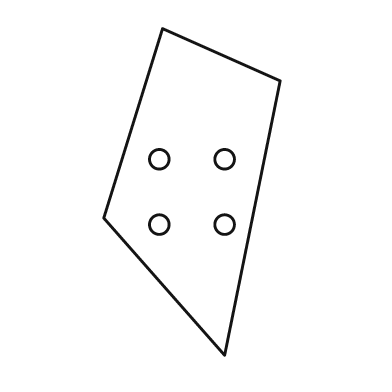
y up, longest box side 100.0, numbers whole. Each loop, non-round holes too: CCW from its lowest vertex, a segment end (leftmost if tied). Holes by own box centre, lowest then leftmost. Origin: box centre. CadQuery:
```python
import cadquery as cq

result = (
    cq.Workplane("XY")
    .moveTo(10.0, -50.0)
    .lineTo(27.0, 34.0)
    .lineTo(-9.0, 50.0)
    .lineTo(-27.0, -8.0)
    .close()
    .moveTo(-10.0, -10.0)
    .circle(3.0)
    .moveTo(10.0, -10.0)
    .circle(3.0)
    .moveTo(-10.0, 10.0)
    .circle(3.0)
    .moveTo(10.0, 10.0)
    .circle(3.0)
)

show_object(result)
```